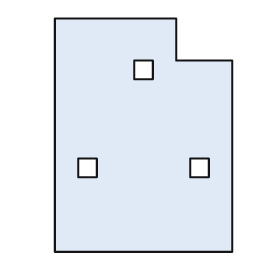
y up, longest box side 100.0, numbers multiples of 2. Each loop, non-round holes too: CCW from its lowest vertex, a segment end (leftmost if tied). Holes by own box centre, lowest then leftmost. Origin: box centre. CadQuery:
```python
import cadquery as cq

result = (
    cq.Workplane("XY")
    .moveTo(-38.0, -50.0)
    .lineTo(38.0, -50.0)
    .lineTo(38.0, 32.0)
    .lineTo(14.0, 32.0)
    .lineTo(14.0, 50.0)
    .lineTo(-38.0, 50.0)
    .close()
    .moveTo(-28.0, -18.0)
    .lineTo(-20.0, -18.0)
    .lineTo(-20.0, -10.0)
    .lineTo(-28.0, -10.0)
    .close()
    .moveTo(20.0, -18.0)
    .lineTo(28.0, -18.0)
    .lineTo(28.0, -10.0)
    .lineTo(20.0, -10.0)
    .close()
    .moveTo(-4.0, 24.0)
    .lineTo(4.0, 24.0)
    .lineTo(4.0, 32.0)
    .lineTo(-4.0, 32.0)
    .close()
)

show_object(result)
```